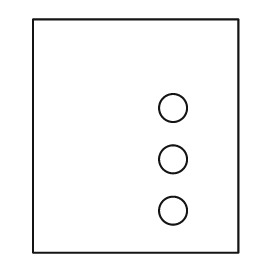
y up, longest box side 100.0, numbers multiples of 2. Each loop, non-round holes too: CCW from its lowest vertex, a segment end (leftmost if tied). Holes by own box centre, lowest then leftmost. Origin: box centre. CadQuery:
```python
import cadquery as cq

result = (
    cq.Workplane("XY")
    .moveTo(-44.0, -50.0)
    .lineTo(44.0, -50.0)
    .lineTo(44.0, 50.0)
    .lineTo(-44.0, 50.0)
    .close()
    .moveTo(16.0, -32.0)
    .circle(6.0)
    .moveTo(16.0, -10.0)
    .circle(6.0)
    .moveTo(16.0, 12.0)
    .circle(6.0)
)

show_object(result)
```